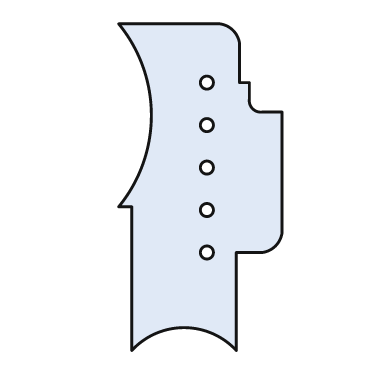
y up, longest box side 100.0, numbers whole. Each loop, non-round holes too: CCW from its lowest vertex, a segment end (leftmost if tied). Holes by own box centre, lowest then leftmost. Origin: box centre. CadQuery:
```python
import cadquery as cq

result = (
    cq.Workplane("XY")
    .moveTo(-21.0, -50.0)
    .threePointArc((-5.0, -43.0), (11.0, -50.0))
    .lineTo(11.0, -20.0)
    .lineTo(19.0, -20.0)
    .threePointArc((23.0, -18.0), (25.0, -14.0))
    .lineTo(25.0, 23.0)
    .lineTo(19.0, 23.0)
    .threePointArc((16.0, 24.0), (15.0, 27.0))
    .lineTo(15.0, 32.0)
    .lineTo(12.0, 32.0)
    .lineTo(12.0, 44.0)
    .threePointArc((10.0, 48.0), (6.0, 50.0))
    .lineTo(-25.0, 50.0)
    .threePointArc((-15.0, 22.0), (-25.0, -6.0))
    .lineTo(-21.0, -6.0)
    .close()
    .moveTo(2.0, -20.0)
    .circle(2.0)
    .moveTo(2.0, -7.0)
    .circle(2.0)
    .moveTo(2.0, 6.0)
    .circle(2.0)
    .moveTo(2.0, 19.0)
    .circle(2.0)
    .moveTo(2.0, 32.0)
    .circle(2.0)
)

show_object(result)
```